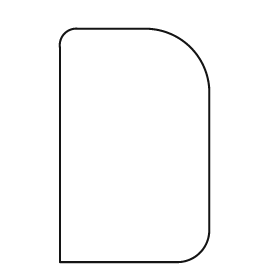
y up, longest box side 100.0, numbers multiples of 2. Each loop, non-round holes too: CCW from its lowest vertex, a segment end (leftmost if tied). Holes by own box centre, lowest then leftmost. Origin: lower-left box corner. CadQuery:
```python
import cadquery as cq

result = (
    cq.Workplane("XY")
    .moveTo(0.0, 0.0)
    .lineTo(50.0, 0.0)
    .threePointArc((60.0, 4.0), (64.0, 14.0))
    .lineTo(64.0, 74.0)
    .threePointArc((56.0, 92.0), (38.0, 100.0))
    .lineTo(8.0, 100.0)
    .threePointArc((2.0, 98.0), (0.0, 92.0))
    .close()
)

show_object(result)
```